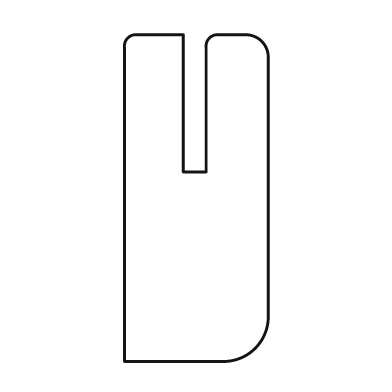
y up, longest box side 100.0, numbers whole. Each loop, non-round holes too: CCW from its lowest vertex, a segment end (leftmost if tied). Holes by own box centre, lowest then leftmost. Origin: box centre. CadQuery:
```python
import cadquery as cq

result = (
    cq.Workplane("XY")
    .moveTo(-22.0, -50.0)
    .lineTo(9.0, -50.0)
    .threePointArc((18.0, -46.0), (22.0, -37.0))
    .lineTo(22.0, 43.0)
    .threePointArc((20.0, 48.0), (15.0, 50.0))
    .lineTo(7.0, 50.0)
    .threePointArc((4.0, 49.0), (3.0, 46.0))
    .lineTo(3.0, 8.0)
    .lineTo(-4.0, 8.0)
    .lineTo(-4.0, 50.0)
    .lineTo(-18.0, 50.0)
    .threePointArc((-21.0, 49.0), (-22.0, 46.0))
    .close()
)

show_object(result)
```